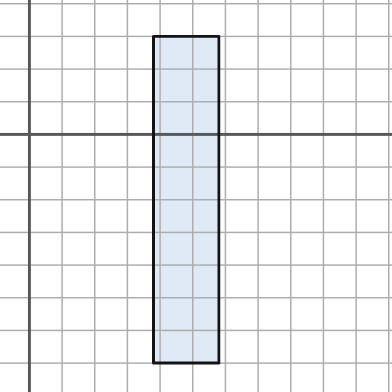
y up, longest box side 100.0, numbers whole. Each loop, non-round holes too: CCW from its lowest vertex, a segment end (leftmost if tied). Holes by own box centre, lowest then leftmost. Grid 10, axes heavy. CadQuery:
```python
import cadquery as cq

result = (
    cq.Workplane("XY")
    .moveTo(38.0, -70.0)
    .lineTo(58.0, -70.0)
    .lineTo(58.0, 30.0)
    .lineTo(38.0, 30.0)
    .close()
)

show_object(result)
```